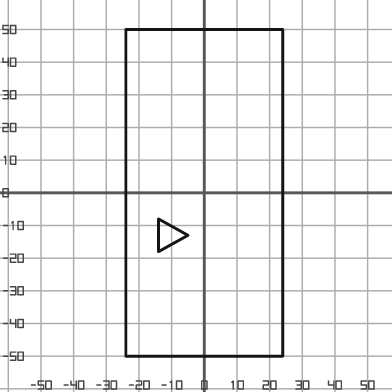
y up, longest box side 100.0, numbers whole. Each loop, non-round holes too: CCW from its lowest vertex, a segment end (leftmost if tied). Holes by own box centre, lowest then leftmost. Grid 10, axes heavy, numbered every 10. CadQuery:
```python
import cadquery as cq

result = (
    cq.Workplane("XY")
    .moveTo(-24.0, -50.0)
    .lineTo(24.0, -50.0)
    .lineTo(24.0, 50.0)
    .lineTo(-24.0, 50.0)
    .close()
    .moveTo(-14.0, -18.0)
    .lineTo(-5.0, -13.0)
    .lineTo(-14.0, -8.0)
    .close()
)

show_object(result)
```